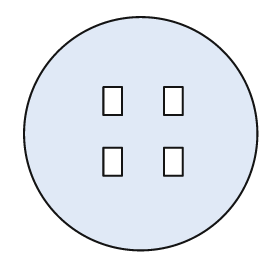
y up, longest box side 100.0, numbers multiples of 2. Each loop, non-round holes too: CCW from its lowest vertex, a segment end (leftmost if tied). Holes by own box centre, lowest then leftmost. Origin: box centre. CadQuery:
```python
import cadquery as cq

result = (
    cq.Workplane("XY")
    .moveTo(0.0, 0.0)
    .circle(50.0)
    .moveTo(-16.0, -18.0)
    .lineTo(-8.0, -18.0)
    .lineTo(-8.0, -6.0)
    .lineTo(-16.0, -6.0)
    .close()
    .moveTo(10.0, -18.0)
    .lineTo(18.0, -18.0)
    .lineTo(18.0, -6.0)
    .lineTo(10.0, -6.0)
    .close()
    .moveTo(-16.0, 8.0)
    .lineTo(-8.0, 8.0)
    .lineTo(-8.0, 20.0)
    .lineTo(-16.0, 20.0)
    .close()
    .moveTo(10.0, 8.0)
    .lineTo(18.0, 8.0)
    .lineTo(18.0, 20.0)
    .lineTo(10.0, 20.0)
    .close()
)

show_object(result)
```